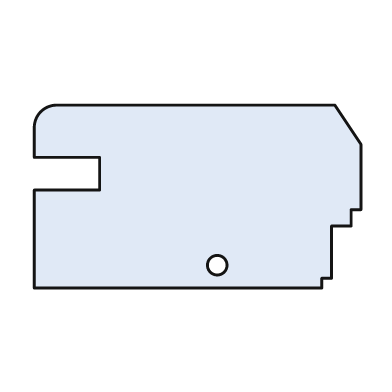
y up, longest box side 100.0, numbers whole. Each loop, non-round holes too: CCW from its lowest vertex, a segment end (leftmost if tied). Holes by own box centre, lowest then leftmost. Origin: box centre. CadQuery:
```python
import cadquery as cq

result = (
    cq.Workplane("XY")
    .moveTo(-50.0, -28.0)
    .lineTo(38.0, -28.0)
    .lineTo(38.0, -25.0)
    .lineTo(41.0, -25.0)
    .lineTo(41.0, -9.0)
    .lineTo(47.0, -9.0)
    .lineTo(47.0, -4.0)
    .lineTo(50.0, -4.0)
    .lineTo(50.0, 16.0)
    .lineTo(42.0, 28.0)
    .lineTo(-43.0, 28.0)
    .threePointArc((-48.0, 26.0), (-50.0, 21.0))
    .lineTo(-50.0, 12.0)
    .lineTo(-30.0, 12.0)
    .lineTo(-30.0, 2.0)
    .lineTo(-50.0, 2.0)
    .close()
    .moveTo(6.0, -21.0)
    .circle(3.0)
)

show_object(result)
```